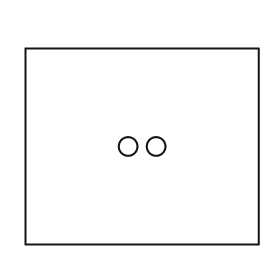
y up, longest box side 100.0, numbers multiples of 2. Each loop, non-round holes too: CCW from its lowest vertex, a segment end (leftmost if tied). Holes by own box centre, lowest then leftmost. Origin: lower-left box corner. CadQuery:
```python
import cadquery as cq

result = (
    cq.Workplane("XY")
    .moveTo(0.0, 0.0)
    .lineTo(100.0, 0.0)
    .lineTo(100.0, 84.0)
    .lineTo(0.0, 84.0)
    .close()
    .moveTo(44.0, 42.0)
    .circle(4.0)
    .moveTo(56.0, 42.0)
    .circle(4.0)
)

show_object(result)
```